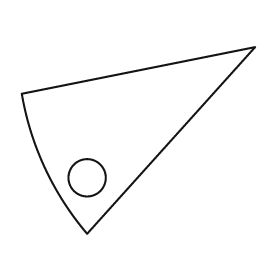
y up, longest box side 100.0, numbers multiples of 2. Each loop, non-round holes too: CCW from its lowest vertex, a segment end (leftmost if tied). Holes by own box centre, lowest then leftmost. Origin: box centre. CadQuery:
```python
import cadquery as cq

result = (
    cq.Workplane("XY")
    .moveTo(-22.0, -40.0)
    .lineTo(50.0, 40.0)
    .lineTo(-50.0, 20.0)
    .threePointArc((-40.0, -12.0), (-22.0, -40.0))
    .close()
    .moveTo(-22.0, -16.0)
    .circle(8.0)
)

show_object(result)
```